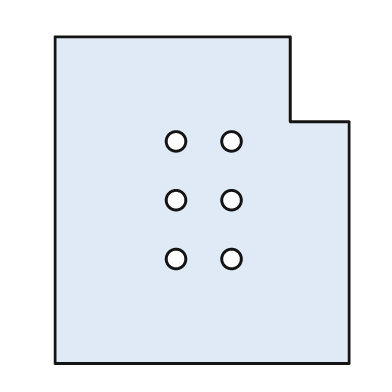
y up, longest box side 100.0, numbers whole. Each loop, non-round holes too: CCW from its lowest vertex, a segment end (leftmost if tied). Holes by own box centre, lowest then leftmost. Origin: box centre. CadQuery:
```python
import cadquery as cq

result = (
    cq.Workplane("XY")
    .moveTo(-45.0, -50.0)
    .lineTo(45.0, -50.0)
    .lineTo(45.0, 24.0)
    .lineTo(27.0, 24.0)
    .lineTo(27.0, 50.0)
    .lineTo(-45.0, 50.0)
    .close()
    .moveTo(-8.0, -18.0)
    .circle(3.0)
    .moveTo(9.0, -18.0)
    .circle(3.0)
    .moveTo(-8.0, 0.0)
    .circle(3.0)
    .moveTo(9.0, 0.0)
    .circle(3.0)
    .moveTo(-8.0, 18.0)
    .circle(3.0)
    .moveTo(9.0, 18.0)
    .circle(3.0)
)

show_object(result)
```